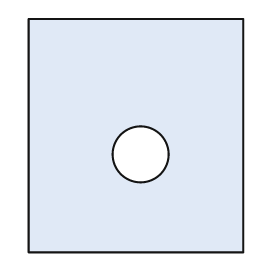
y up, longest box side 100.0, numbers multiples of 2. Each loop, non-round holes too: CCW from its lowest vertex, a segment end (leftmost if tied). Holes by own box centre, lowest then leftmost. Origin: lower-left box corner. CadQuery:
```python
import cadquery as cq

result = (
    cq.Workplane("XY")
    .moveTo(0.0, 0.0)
    .lineTo(92.0, 0.0)
    .lineTo(92.0, 100.0)
    .lineTo(0.0, 100.0)
    .close()
    .moveTo(48.0, 42.0)
    .circle(12.0)
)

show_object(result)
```